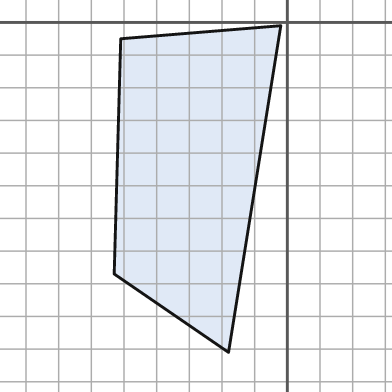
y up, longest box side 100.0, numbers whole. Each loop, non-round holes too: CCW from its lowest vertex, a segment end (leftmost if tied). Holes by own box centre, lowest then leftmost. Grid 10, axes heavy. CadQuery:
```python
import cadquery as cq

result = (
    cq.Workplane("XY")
    .moveTo(-18.0, -101.0)
    .lineTo(-2.0, -1.0)
    .lineTo(-51.0, -5.0)
    .lineTo(-53.0, -77.0)
    .close()
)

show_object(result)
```